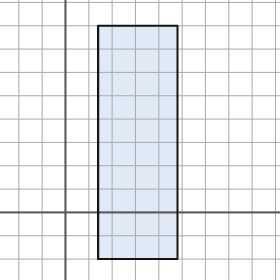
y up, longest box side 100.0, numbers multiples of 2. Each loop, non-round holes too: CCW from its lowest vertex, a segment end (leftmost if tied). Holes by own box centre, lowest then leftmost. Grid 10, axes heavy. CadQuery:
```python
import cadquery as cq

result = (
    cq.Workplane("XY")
    .moveTo(14.0, -20.0)
    .lineTo(48.0, -20.0)
    .lineTo(48.0, 80.0)
    .lineTo(14.0, 80.0)
    .close()
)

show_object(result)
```